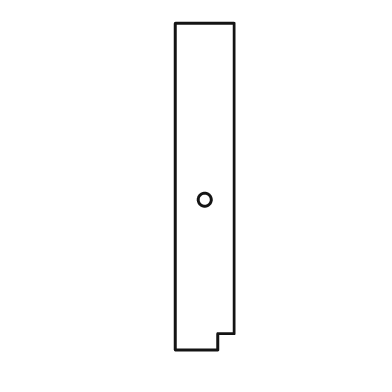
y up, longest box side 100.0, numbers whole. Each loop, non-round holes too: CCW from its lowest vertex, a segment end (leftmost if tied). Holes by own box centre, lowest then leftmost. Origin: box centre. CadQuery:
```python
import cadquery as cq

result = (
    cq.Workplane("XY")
    .moveTo(-9.0, -50.0)
    .lineTo(4.0, -50.0)
    .lineTo(4.0, -45.0)
    .lineTo(9.0, -45.0)
    .lineTo(9.0, 50.0)
    .lineTo(-9.0, 50.0)
    .close()
    .moveTo(0.0, -4.0)
    .circle(2.0)
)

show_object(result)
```